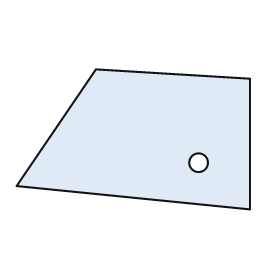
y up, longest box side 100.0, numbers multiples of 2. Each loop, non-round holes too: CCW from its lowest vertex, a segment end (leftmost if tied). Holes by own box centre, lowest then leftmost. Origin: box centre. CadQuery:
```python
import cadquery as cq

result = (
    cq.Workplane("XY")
    .moveTo(50.0, -30.0)
    .lineTo(50.0, 26.0)
    .lineTo(-16.0, 30.0)
    .lineTo(-50.0, -20.0)
    .close()
    .moveTo(28.0, -10.0)
    .circle(4.0)
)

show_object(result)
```